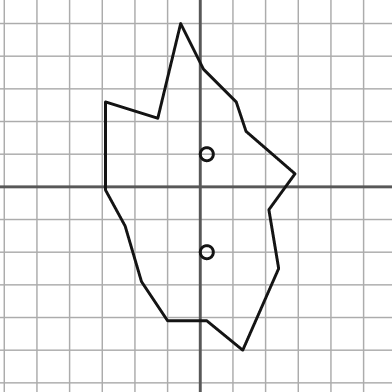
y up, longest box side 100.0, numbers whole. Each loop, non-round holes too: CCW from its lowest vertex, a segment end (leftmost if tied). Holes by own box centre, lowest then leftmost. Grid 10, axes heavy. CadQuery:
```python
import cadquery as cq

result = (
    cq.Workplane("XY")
    .moveTo(13.0, -50.0)
    .lineTo(24.0, -25.0)
    .lineTo(21.0, -7.0)
    .lineTo(29.0, 4.0)
    .lineTo(14.0, 17.0)
    .lineTo(11.0, 26.0)
    .lineTo(1.0, 36.0)
    .lineTo(-6.0, 50.0)
    .lineTo(-13.0, 21.0)
    .lineTo(-29.0, 26.0)
    .lineTo(-29.0, -1.0)
    .lineTo(-23.0, -12.0)
    .lineTo(-18.0, -29.0)
    .lineTo(-10.0, -41.0)
    .lineTo(2.0, -41.0)
    .close()
    .moveTo(2.0, -20.0)
    .circle(2.0)
    .moveTo(2.0, 10.0)
    .circle(2.0)
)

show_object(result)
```